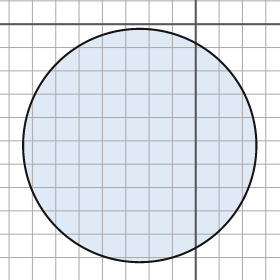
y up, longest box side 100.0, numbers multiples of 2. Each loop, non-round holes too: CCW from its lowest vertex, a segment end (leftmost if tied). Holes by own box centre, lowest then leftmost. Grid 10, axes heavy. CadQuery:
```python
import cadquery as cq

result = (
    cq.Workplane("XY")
    .moveTo(-24.0, -52.0)
    .circle(50.0)
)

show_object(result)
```